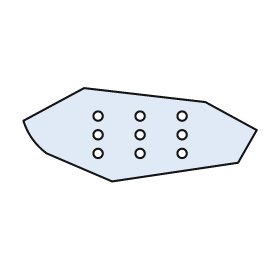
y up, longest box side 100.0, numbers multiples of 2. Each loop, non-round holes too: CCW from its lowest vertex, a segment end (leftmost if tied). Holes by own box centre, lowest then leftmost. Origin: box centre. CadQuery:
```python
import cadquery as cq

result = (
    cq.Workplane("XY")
    .moveTo(-12.0, -20.0)
    .lineTo(42.0, -12.0)
    .lineTo(50.0, 2.0)
    .lineTo(28.0, 14.0)
    .lineTo(-24.0, 20.0)
    .lineTo(-50.0, 6.0)
    .threePointArc((-46.0, -2.0), (-40.0, -8.0))
    .close()
    .moveTo(-18.0, -8.0)
    .circle(2.0)
    .moveTo(0.0, -8.0)
    .circle(2.0)
    .moveTo(18.0, -8.0)
    .circle(2.0)
    .moveTo(-18.0, 0.0)
    .circle(2.0)
    .moveTo(0.0, 0.0)
    .circle(2.0)
    .moveTo(18.0, 0.0)
    .circle(2.0)
    .moveTo(-18.0, 8.0)
    .circle(2.0)
    .moveTo(0.0, 8.0)
    .circle(2.0)
    .moveTo(18.0, 8.0)
    .circle(2.0)
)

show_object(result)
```